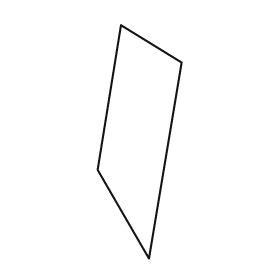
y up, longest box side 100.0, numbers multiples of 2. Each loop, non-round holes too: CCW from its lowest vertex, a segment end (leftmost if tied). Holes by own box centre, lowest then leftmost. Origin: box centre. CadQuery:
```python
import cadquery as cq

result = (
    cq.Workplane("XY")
    .moveTo(4.0, -50.0)
    .lineTo(18.0, 34.0)
    .lineTo(-8.0, 50.0)
    .lineTo(-18.0, -12.0)
    .close()
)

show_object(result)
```